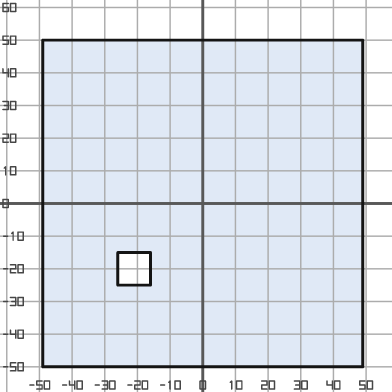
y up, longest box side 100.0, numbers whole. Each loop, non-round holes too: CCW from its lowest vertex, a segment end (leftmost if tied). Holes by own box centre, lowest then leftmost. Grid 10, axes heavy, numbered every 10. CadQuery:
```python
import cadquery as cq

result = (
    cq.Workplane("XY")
    .moveTo(-49.0, -50.0)
    .lineTo(49.0, -50.0)
    .lineTo(49.0, 50.0)
    .lineTo(-49.0, 50.0)
    .close()
    .moveTo(-26.0, -25.0)
    .lineTo(-16.0, -25.0)
    .lineTo(-16.0, -15.0)
    .lineTo(-26.0, -15.0)
    .close()
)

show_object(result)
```